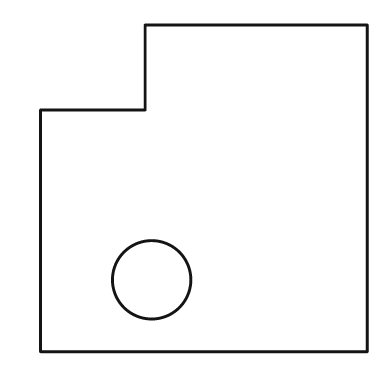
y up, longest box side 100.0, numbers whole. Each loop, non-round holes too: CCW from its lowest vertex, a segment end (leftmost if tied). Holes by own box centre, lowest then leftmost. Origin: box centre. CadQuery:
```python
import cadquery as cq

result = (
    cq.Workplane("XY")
    .moveTo(-50.0, -50.0)
    .lineTo(50.0, -50.0)
    .lineTo(50.0, 50.0)
    .lineTo(-18.0, 50.0)
    .lineTo(-18.0, 24.0)
    .lineTo(-50.0, 24.0)
    .close()
    .moveTo(-16.0, -28.0)
    .circle(12.0)
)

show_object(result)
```